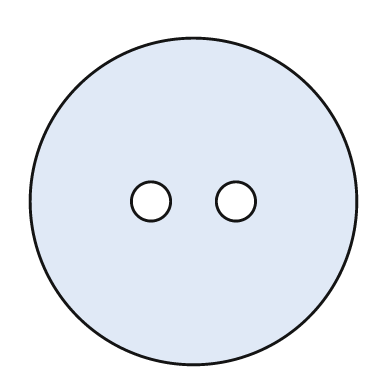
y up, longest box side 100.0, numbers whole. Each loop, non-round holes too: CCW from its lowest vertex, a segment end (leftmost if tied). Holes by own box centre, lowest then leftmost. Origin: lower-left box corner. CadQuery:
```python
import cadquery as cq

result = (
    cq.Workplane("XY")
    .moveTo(50.0, 50.0)
    .circle(50.0)
    .moveTo(37.0, 50.0)
    .circle(6.0)
    .moveTo(63.0, 50.0)
    .circle(6.0)
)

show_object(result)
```